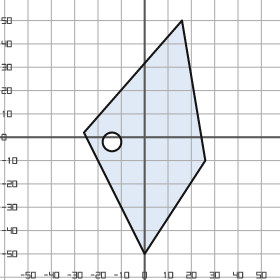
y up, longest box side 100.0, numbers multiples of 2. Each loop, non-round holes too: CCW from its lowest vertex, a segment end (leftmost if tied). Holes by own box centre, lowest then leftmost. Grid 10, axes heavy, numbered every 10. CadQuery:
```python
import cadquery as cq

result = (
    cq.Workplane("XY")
    .moveTo(0.0, -50.0)
    .lineTo(26.0, -10.0)
    .lineTo(16.0, 50.0)
    .lineTo(-26.0, 2.0)
    .close()
    .moveTo(-14.0, -2.0)
    .circle(4.0)
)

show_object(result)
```